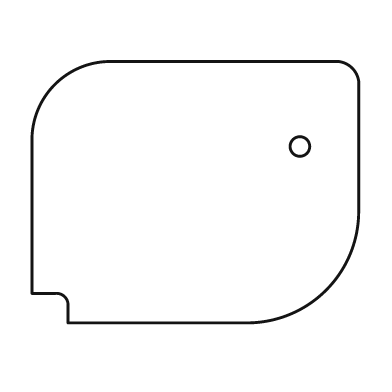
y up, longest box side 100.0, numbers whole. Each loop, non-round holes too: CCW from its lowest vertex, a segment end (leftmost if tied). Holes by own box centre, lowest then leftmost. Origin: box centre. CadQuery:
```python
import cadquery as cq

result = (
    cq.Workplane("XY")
    .moveTo(-39.0, -40.0)
    .lineTo(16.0, -40.0)
    .threePointArc((40.0, -30.0), (50.0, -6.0))
    .lineTo(50.0, 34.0)
    .threePointArc((48.0, 38.0), (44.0, 40.0))
    .lineTo(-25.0, 40.0)
    .threePointArc((-43.0, 33.0), (-50.0, 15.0))
    .lineTo(-50.0, -31.0)
    .lineTo(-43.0, -31.0)
    .threePointArc((-40.0, -32.0), (-39.0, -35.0))
    .close()
    .moveTo(32.0, 14.0)
    .circle(3.0)
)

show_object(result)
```